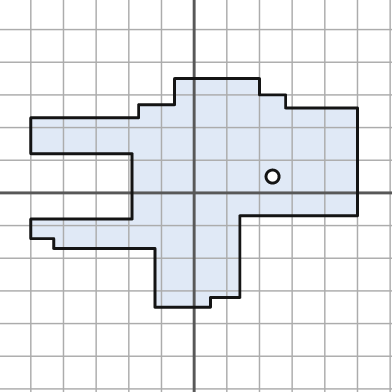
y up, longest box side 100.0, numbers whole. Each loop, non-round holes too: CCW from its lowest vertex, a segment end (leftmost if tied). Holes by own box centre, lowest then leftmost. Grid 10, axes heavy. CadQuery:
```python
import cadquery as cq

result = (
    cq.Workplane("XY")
    .moveTo(-12.0, -35.0)
    .lineTo(5.0, -35.0)
    .lineTo(5.0, -32.0)
    .lineTo(14.0, -32.0)
    .lineTo(14.0, -7.0)
    .lineTo(50.0, -7.0)
    .lineTo(50.0, 26.0)
    .lineTo(28.0, 26.0)
    .lineTo(28.0, 30.0)
    .lineTo(20.0, 30.0)
    .lineTo(20.0, 35.0)
    .lineTo(-6.0, 35.0)
    .lineTo(-6.0, 27.0)
    .lineTo(-17.0, 27.0)
    .lineTo(-17.0, 23.0)
    .lineTo(-50.0, 23.0)
    .lineTo(-50.0, 12.0)
    .lineTo(-19.0, 12.0)
    .lineTo(-19.0, -8.0)
    .lineTo(-50.0, -8.0)
    .lineTo(-50.0, -14.0)
    .lineTo(-43.0, -14.0)
    .lineTo(-43.0, -17.0)
    .lineTo(-12.0, -17.0)
    .close()
    .moveTo(24.0, 5.0)
    .circle(2.0)
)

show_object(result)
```